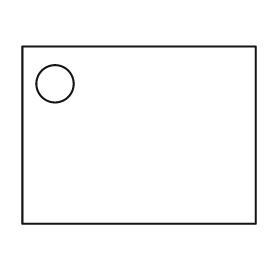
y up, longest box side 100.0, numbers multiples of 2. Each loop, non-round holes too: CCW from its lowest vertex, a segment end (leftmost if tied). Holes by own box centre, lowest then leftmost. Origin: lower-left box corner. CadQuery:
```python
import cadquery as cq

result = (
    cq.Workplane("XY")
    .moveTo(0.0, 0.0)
    .lineTo(100.0, 0.0)
    .lineTo(100.0, 76.0)
    .lineTo(0.0, 76.0)
    .close()
    .moveTo(14.0, 60.0)
    .circle(8.0)
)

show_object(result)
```